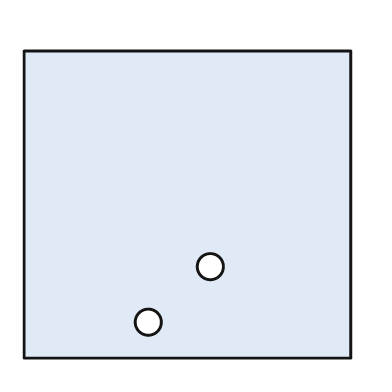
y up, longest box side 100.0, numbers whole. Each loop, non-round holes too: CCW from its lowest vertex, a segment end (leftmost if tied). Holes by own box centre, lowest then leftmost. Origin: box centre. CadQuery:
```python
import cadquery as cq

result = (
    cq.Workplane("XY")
    .moveTo(-50.0, -47.0)
    .lineTo(50.0, -47.0)
    .lineTo(50.0, 47.0)
    .lineTo(-50.0, 47.0)
    .close()
    .moveTo(-12.0, -36.0)
    .circle(4.0)
    .moveTo(7.0, -19.0)
    .circle(4.0)
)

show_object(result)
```